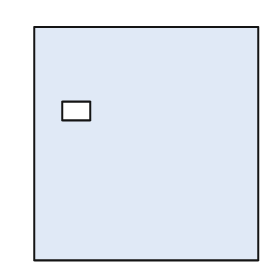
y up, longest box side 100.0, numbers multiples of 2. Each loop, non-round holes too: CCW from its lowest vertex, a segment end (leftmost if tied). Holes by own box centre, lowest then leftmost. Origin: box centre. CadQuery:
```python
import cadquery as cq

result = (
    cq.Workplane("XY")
    .moveTo(-48.0, -50.0)
    .lineTo(48.0, -50.0)
    .lineTo(48.0, 50.0)
    .lineTo(-48.0, 50.0)
    .close()
    .moveTo(-36.0, 10.0)
    .lineTo(-24.0, 10.0)
    .lineTo(-24.0, 18.0)
    .lineTo(-36.0, 18.0)
    .close()
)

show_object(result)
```